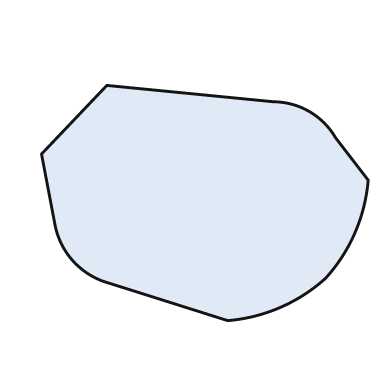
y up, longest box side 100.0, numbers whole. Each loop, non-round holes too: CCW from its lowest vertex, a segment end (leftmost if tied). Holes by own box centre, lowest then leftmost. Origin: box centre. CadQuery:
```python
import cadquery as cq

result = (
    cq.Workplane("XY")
    .moveTo(7.0, -36.0)
    .threePointArc((23.0, -32.0), (37.0, -23.0))
    .threePointArc((46.0, -9.0), (50.0, 7.0))
    .lineTo(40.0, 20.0)
    .threePointArc((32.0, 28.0), (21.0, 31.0))
    .lineTo(-30.0, 36.0)
    .lineTo(-50.0, 15.0)
    .lineTo(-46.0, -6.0)
    .threePointArc((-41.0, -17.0), (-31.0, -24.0))
    .close()
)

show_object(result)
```